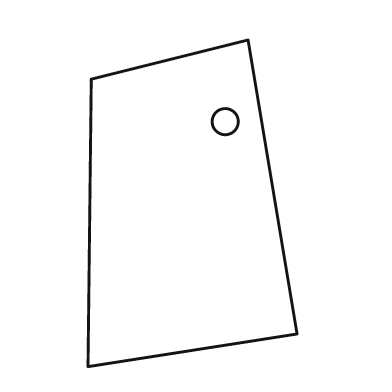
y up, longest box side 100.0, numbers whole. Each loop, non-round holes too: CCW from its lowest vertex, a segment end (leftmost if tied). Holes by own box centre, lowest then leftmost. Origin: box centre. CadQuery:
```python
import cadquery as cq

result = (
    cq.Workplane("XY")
    .moveTo(-32.0, -50.0)
    .lineTo(32.0, -40.0)
    .lineTo(17.0, 50.0)
    .lineTo(-31.0, 38.0)
    .close()
    .moveTo(10.0, 25.0)
    .circle(4.0)
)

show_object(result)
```